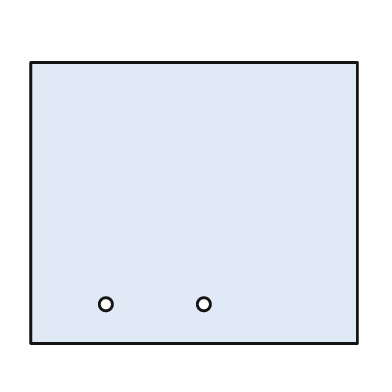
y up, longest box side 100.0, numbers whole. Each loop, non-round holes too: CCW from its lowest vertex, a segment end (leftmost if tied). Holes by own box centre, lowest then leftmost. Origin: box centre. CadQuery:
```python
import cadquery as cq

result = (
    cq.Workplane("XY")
    .moveTo(-50.0, -43.0)
    .lineTo(50.0, -43.0)
    .lineTo(50.0, 43.0)
    .lineTo(-50.0, 43.0)
    .close()
    .moveTo(-27.0, -31.0)
    .circle(2.0)
    .moveTo(3.0, -31.0)
    .circle(2.0)
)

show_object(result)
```